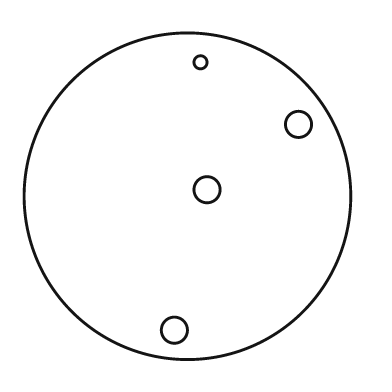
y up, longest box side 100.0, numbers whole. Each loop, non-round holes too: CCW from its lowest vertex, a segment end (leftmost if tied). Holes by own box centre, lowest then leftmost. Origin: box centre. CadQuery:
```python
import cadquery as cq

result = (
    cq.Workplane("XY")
    .moveTo(0.0, 0.0)
    .circle(50.0)
    .moveTo(-4.0, -41.0)
    .circle(4.0)
    .moveTo(6.0, 2.0)
    .circle(4.0)
    .moveTo(34.0, 22.0)
    .circle(4.0)
    .moveTo(4.0, 41.0)
    .circle(2.0)
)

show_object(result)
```